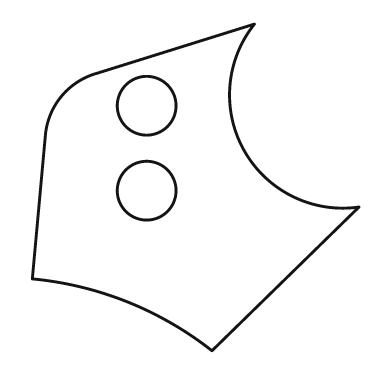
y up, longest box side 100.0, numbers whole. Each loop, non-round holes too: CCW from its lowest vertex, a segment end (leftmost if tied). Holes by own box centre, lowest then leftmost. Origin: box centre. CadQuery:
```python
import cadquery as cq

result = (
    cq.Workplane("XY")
    .moveTo(5.0, -50.0)
    .lineTo(50.0, -6.0)
    .threePointArc((15.0, 11.0), (18.0, 50.0))
    .lineTo(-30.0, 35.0)
    .threePointArc((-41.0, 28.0), (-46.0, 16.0))
    .lineTo(-50.0, -28.0)
    .threePointArc((-21.0, -35.0), (5.0, -50.0))
    .close()
    .moveTo(-15.0, -1.0)
    .circle(9.0)
    .moveTo(-15.0, 25.0)
    .circle(9.0)
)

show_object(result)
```